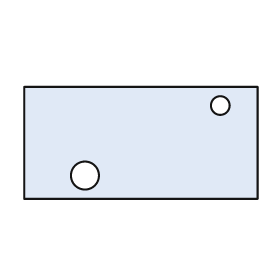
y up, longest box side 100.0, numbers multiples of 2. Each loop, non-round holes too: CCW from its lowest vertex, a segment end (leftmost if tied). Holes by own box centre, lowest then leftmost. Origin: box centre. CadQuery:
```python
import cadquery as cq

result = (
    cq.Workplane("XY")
    .moveTo(-50.0, -24.0)
    .lineTo(50.0, -24.0)
    .lineTo(50.0, 24.0)
    .lineTo(-50.0, 24.0)
    .close()
    .moveTo(-24.0, -14.0)
    .circle(6.0)
    .moveTo(34.0, 16.0)
    .circle(4.0)
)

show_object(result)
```